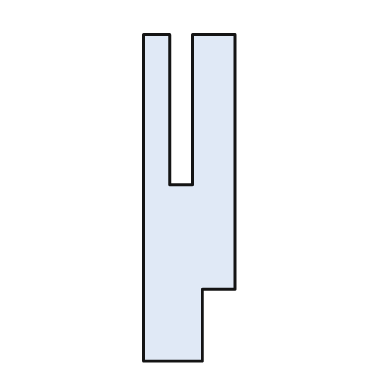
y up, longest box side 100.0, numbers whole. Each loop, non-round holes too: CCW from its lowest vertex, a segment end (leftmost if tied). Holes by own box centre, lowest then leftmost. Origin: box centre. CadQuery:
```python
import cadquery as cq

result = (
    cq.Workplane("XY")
    .moveTo(-14.0, -50.0)
    .lineTo(4.0, -50.0)
    .lineTo(4.0, -28.0)
    .lineTo(14.0, -28.0)
    .lineTo(14.0, 50.0)
    .lineTo(1.0, 50.0)
    .lineTo(1.0, 4.0)
    .lineTo(-6.0, 4.0)
    .lineTo(-6.0, 50.0)
    .lineTo(-14.0, 50.0)
    .close()
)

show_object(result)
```